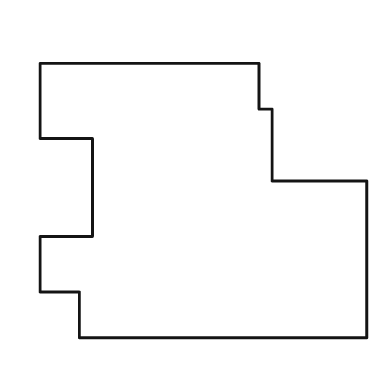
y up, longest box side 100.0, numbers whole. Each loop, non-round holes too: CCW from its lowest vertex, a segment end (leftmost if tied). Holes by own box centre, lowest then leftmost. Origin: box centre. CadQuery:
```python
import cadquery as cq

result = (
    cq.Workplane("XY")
    .moveTo(-38.0, -42.0)
    .lineTo(50.0, -42.0)
    .lineTo(50.0, 6.0)
    .lineTo(21.0, 6.0)
    .lineTo(21.0, 28.0)
    .lineTo(17.0, 28.0)
    .lineTo(17.0, 42.0)
    .lineTo(-50.0, 42.0)
    .lineTo(-50.0, 19.0)
    .lineTo(-34.0, 19.0)
    .lineTo(-34.0, -11.0)
    .lineTo(-50.0, -11.0)
    .lineTo(-50.0, -28.0)
    .lineTo(-38.0, -28.0)
    .close()
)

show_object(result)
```